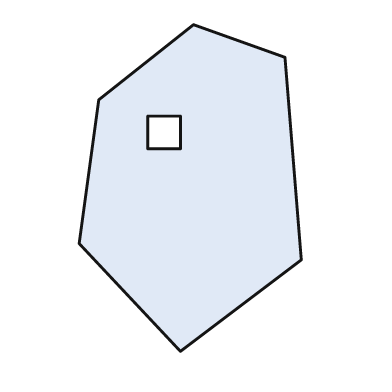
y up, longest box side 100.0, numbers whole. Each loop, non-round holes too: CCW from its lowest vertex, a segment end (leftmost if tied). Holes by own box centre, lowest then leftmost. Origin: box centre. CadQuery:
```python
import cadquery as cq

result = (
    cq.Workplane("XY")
    .moveTo(-3.0, -50.0)
    .lineTo(34.0, -22.0)
    .lineTo(29.0, 40.0)
    .lineTo(1.0, 50.0)
    .lineTo(-28.0, 27.0)
    .lineTo(-34.0, -17.0)
    .close()
    .moveTo(-13.0, 12.0)
    .lineTo(-3.0, 12.0)
    .lineTo(-3.0, 22.0)
    .lineTo(-13.0, 22.0)
    .close()
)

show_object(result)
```